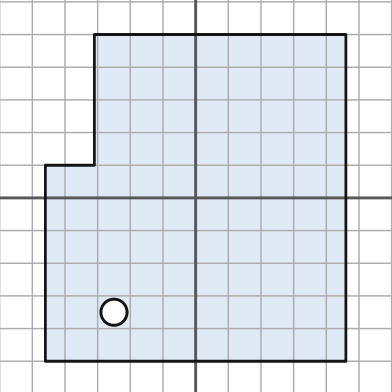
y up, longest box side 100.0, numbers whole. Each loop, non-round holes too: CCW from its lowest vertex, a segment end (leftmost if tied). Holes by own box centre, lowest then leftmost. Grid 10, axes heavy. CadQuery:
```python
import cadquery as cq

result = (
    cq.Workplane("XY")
    .moveTo(-46.0, -50.0)
    .lineTo(46.0, -50.0)
    .lineTo(46.0, 50.0)
    .lineTo(-31.0, 50.0)
    .lineTo(-31.0, 10.0)
    .lineTo(-46.0, 10.0)
    .close()
    .moveTo(-25.0, -35.0)
    .circle(4.0)
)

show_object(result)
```